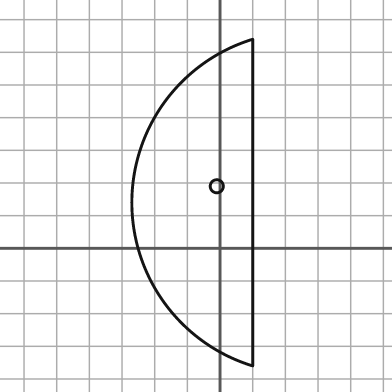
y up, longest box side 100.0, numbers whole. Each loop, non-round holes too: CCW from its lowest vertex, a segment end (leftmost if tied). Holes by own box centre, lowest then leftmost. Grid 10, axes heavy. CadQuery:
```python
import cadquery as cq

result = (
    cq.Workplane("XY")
    .moveTo(10.0, -36.0)
    .lineTo(10.0, 64.0)
    .threePointArc((-27.0, 14.0), (10.0, -36.0))
    .close()
    .moveTo(-1.0, 19.0)
    .circle(2.0)
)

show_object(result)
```